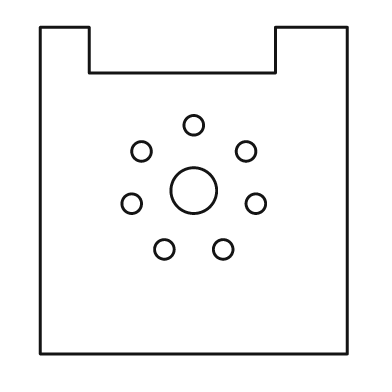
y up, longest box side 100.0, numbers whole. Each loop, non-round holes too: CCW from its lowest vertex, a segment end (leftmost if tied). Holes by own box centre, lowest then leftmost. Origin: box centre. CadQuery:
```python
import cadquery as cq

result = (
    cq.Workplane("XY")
    .moveTo(-47.0, -50.0)
    .lineTo(47.0, -50.0)
    .lineTo(47.0, 50.0)
    .lineTo(25.0, 50.0)
    .lineTo(25.0, 36.0)
    .lineTo(-32.0, 36.0)
    .lineTo(-32.0, 50.0)
    .lineTo(-47.0, 50.0)
    .close()
    .moveTo(-9.0, -18.0)
    .circle(3.0)
    .moveTo(9.0, -18.0)
    .circle(3.0)
    .moveTo(-19.0, -4.0)
    .circle(3.0)
    .moveTo(19.0, -4.0)
    .circle(3.0)
    .moveTo(0.0, 0.0)
    .circle(7.0)
    .moveTo(-16.0, 12.0)
    .circle(3.0)
    .moveTo(16.0, 12.0)
    .circle(3.0)
    .moveTo(0.0, 20.0)
    .circle(3.0)
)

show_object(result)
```